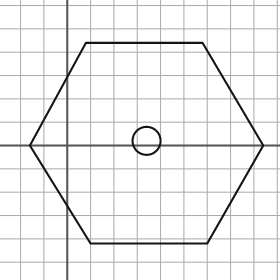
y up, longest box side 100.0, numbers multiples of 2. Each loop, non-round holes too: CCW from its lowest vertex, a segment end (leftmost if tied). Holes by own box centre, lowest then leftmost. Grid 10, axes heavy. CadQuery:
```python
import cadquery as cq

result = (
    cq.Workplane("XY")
    .moveTo(10.0, -42.0)
    .lineTo(60.0, -42.0)
    .lineTo(84.0, 0.0)
    .lineTo(58.0, 44.0)
    .lineTo(8.0, 44.0)
    .lineTo(-16.0, 0.0)
    .close()
    .moveTo(34.0, 2.0)
    .circle(6.0)
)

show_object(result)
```